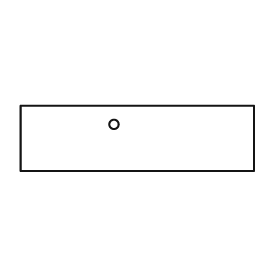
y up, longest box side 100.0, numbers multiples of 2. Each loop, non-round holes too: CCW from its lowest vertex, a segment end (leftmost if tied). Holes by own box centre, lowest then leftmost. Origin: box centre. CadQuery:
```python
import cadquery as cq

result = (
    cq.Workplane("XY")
    .moveTo(-50.0, -14.0)
    .lineTo(50.0, -14.0)
    .lineTo(50.0, 14.0)
    .lineTo(-50.0, 14.0)
    .close()
    .moveTo(-10.0, 6.0)
    .circle(2.0)
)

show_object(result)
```